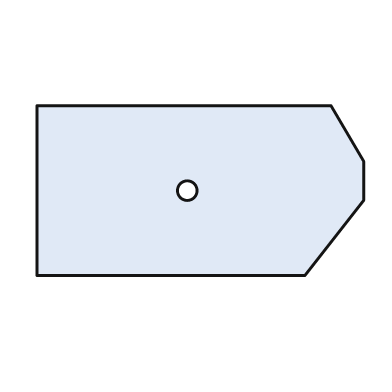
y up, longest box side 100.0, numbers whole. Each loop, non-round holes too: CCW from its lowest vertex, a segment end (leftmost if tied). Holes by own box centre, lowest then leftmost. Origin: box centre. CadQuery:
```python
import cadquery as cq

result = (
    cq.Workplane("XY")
    .moveTo(-50.0, -26.0)
    .lineTo(32.0, -26.0)
    .lineTo(50.0, -3.0)
    .lineTo(50.0, 9.0)
    .lineTo(40.0, 26.0)
    .lineTo(-50.0, 26.0)
    .close()
    .moveTo(-4.0, 0.0)
    .circle(3.0)
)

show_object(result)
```